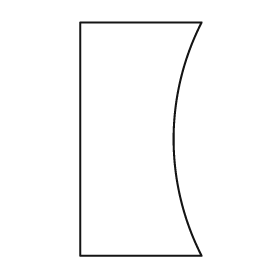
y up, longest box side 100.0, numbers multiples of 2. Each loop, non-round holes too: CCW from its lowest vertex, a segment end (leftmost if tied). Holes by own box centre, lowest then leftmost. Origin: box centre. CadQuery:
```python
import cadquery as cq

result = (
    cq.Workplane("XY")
    .moveTo(-26.0, -50.0)
    .lineTo(26.0, -50.0)
    .threePointArc((14.0, 0.0), (26.0, 50.0))
    .lineTo(-26.0, 50.0)
    .close()
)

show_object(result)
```